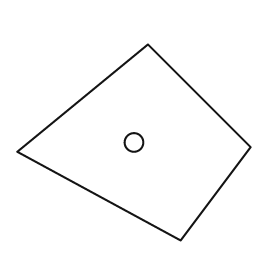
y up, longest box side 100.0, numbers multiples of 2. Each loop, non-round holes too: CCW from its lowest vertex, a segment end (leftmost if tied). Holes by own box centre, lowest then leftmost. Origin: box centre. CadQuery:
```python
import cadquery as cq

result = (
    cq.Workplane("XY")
    .moveTo(20.0, -42.0)
    .lineTo(50.0, -2.0)
    .lineTo(6.0, 42.0)
    .lineTo(-50.0, -4.0)
    .close()
    .moveTo(0.0, 0.0)
    .circle(4.0)
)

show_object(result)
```